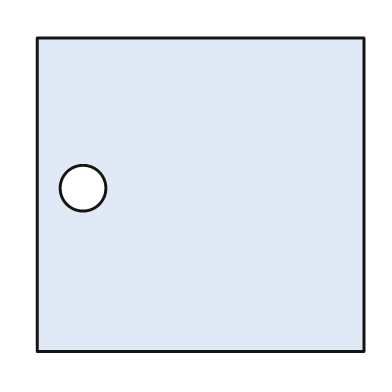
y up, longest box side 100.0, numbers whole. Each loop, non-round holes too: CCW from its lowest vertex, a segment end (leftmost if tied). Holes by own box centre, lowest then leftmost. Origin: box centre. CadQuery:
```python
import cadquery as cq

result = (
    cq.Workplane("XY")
    .moveTo(-50.0, -48.0)
    .lineTo(50.0, -48.0)
    .lineTo(50.0, 48.0)
    .lineTo(-50.0, 48.0)
    .close()
    .moveTo(-36.0, 2.0)
    .circle(7.0)
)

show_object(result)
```